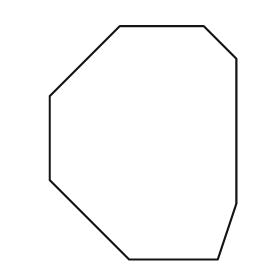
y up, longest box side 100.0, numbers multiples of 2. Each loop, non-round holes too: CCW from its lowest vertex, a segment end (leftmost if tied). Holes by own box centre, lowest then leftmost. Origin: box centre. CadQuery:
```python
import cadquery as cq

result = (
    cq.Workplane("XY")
    .moveTo(-6.0, -50.0)
    .lineTo(32.0, -50.0)
    .lineTo(40.0, -26.0)
    .lineTo(40.0, 36.0)
    .lineTo(26.0, 50.0)
    .lineTo(-10.0, 50.0)
    .lineTo(-40.0, 20.0)
    .lineTo(-40.0, -16.0)
    .close()
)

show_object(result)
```